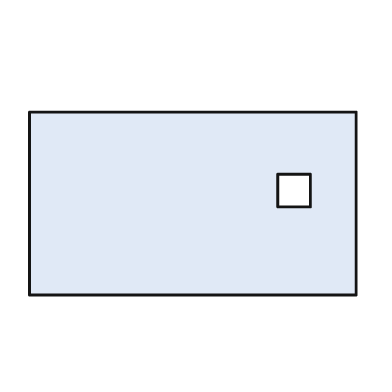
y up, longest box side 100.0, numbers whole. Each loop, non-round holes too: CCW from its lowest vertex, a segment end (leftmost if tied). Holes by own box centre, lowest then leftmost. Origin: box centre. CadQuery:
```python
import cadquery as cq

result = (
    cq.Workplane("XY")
    .moveTo(-50.0, -28.0)
    .lineTo(50.0, -28.0)
    .lineTo(50.0, 28.0)
    .lineTo(-50.0, 28.0)
    .close()
    .moveTo(26.0, -1.0)
    .lineTo(36.0, -1.0)
    .lineTo(36.0, 9.0)
    .lineTo(26.0, 9.0)
    .close()
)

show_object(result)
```